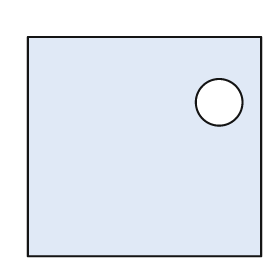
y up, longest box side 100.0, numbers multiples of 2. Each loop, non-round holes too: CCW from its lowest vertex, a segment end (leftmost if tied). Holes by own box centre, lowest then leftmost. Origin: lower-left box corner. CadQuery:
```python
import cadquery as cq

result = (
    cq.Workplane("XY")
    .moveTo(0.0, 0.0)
    .lineTo(100.0, 0.0)
    .lineTo(100.0, 94.0)
    .lineTo(0.0, 94.0)
    .close()
    .moveTo(82.0, 66.0)
    .circle(10.0)
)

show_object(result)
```